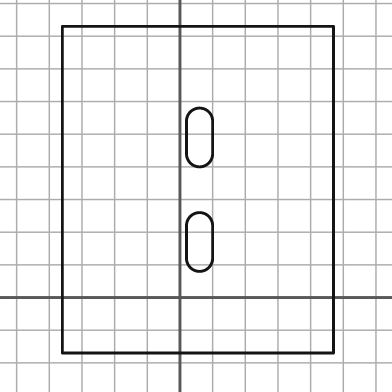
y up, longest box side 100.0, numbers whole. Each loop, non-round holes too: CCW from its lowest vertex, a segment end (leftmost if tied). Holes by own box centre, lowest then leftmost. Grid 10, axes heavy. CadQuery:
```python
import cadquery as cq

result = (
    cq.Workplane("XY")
    .moveTo(-36.0, -17.0)
    .lineTo(47.0, -17.0)
    .lineTo(47.0, 83.0)
    .lineTo(-36.0, 83.0)
    .close()
    .moveTo(2.0, 12.0)
    .threePointArc((6.0, 8.0), (10.0, 12.0))
    .lineTo(10.0, 22.0)
    .threePointArc((6.0, 26.0), (2.0, 22.0))
    .close()
    .moveTo(2.0, 44.0)
    .threePointArc((6.0, 40.0), (10.0, 44.0))
    .lineTo(10.0, 54.0)
    .threePointArc((6.0, 58.0), (2.0, 54.0))
    .close()
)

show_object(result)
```